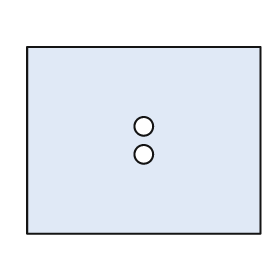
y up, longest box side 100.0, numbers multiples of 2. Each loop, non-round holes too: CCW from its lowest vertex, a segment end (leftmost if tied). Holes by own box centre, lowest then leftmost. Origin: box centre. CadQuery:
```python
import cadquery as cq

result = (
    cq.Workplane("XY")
    .moveTo(-50.0, -40.0)
    .lineTo(50.0, -40.0)
    .lineTo(50.0, 40.0)
    .lineTo(-50.0, 40.0)
    .close()
    .moveTo(0.0, -6.0)
    .circle(4.0)
    .moveTo(0.0, 6.0)
    .circle(4.0)
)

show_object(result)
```